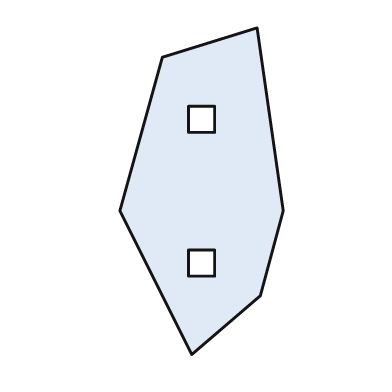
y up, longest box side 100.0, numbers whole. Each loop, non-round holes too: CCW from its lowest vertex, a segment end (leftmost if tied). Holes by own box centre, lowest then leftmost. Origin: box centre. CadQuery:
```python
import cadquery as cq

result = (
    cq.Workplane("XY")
    .moveTo(-3.0, -50.0)
    .lineTo(18.0, -32.0)
    .lineTo(25.0, -6.0)
    .lineTo(17.0, 50.0)
    .lineTo(-12.0, 41.0)
    .lineTo(-25.0, -6.0)
    .close()
    .moveTo(-4.0, -26.0)
    .lineTo(4.0, -26.0)
    .lineTo(4.0, -18.0)
    .lineTo(-4.0, -18.0)
    .close()
    .moveTo(-4.0, 18.0)
    .lineTo(4.0, 18.0)
    .lineTo(4.0, 26.0)
    .lineTo(-4.0, 26.0)
    .close()
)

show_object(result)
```